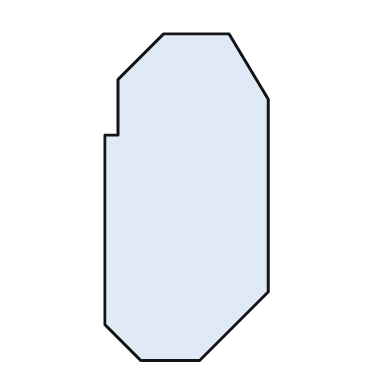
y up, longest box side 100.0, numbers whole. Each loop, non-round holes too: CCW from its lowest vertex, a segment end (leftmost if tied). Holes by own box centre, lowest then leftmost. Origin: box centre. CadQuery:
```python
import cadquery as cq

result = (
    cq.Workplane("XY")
    .moveTo(-14.0, -50.0)
    .lineTo(4.0, -50.0)
    .lineTo(25.0, -29.0)
    .lineTo(25.0, 30.0)
    .lineTo(13.0, 50.0)
    .lineTo(-7.0, 50.0)
    .lineTo(-21.0, 36.0)
    .lineTo(-21.0, 19.0)
    .lineTo(-25.0, 19.0)
    .lineTo(-25.0, -39.0)
    .close()
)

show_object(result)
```